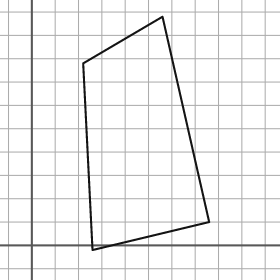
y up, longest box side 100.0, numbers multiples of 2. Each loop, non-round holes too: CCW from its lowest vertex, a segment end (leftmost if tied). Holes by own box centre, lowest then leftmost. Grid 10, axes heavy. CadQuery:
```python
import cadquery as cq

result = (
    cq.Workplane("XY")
    .moveTo(26.0, -2.0)
    .lineTo(76.0, 10.0)
    .lineTo(56.0, 98.0)
    .lineTo(22.0, 78.0)
    .close()
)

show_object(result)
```